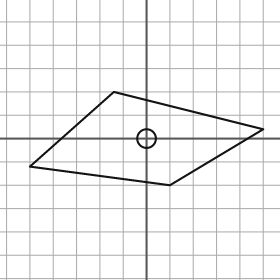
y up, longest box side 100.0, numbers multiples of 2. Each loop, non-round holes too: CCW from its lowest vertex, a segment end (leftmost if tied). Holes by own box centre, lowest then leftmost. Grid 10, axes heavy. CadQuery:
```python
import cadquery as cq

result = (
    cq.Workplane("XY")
    .moveTo(10.0, -20.0)
    .lineTo(50.0, 4.0)
    .lineTo(-14.0, 20.0)
    .lineTo(-50.0, -12.0)
    .close()
    .moveTo(0.0, 0.0)
    .circle(4.0)
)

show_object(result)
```